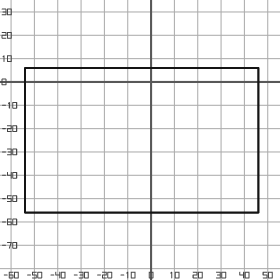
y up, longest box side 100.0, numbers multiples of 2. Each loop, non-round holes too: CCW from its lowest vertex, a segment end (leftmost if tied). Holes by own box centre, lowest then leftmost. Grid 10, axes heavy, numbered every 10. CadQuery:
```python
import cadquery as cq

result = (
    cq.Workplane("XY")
    .moveTo(-54.0, -56.0)
    .lineTo(46.0, -56.0)
    .lineTo(46.0, 6.0)
    .lineTo(-54.0, 6.0)
    .close()
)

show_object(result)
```